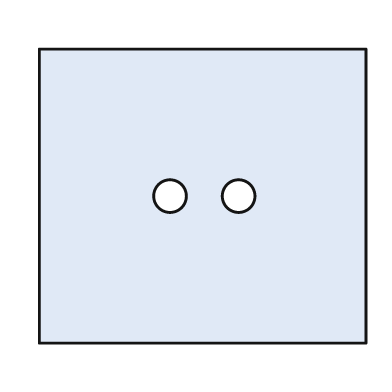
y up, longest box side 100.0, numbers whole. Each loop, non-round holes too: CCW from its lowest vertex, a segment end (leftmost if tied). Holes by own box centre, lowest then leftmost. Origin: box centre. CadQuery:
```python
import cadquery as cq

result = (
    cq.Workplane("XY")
    .moveTo(-50.0, -45.0)
    .lineTo(50.0, -45.0)
    .lineTo(50.0, 45.0)
    .lineTo(-50.0, 45.0)
    .close()
    .moveTo(-10.0, 0.0)
    .circle(5.0)
    .moveTo(11.0, 0.0)
    .circle(5.0)
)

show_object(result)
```